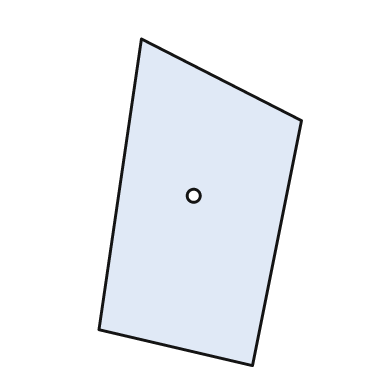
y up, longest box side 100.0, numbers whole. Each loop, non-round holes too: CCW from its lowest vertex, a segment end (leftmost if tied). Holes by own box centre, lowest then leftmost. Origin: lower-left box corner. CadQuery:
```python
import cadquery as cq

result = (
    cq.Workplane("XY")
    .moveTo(47.0, 0.0)
    .lineTo(62.0, 75.0)
    .lineTo(13.0, 100.0)
    .lineTo(0.0, 11.0)
    .close()
    .moveTo(29.0, 52.0)
    .circle(2.0)
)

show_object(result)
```